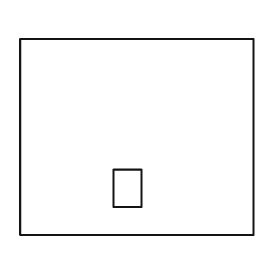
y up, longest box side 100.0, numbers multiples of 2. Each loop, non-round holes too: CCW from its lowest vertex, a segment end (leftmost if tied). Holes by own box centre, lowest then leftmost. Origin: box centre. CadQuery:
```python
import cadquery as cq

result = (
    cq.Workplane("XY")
    .moveTo(-50.0, -42.0)
    .lineTo(50.0, -42.0)
    .lineTo(50.0, 42.0)
    .lineTo(-50.0, 42.0)
    .close()
    .moveTo(-10.0, -30.0)
    .lineTo(2.0, -30.0)
    .lineTo(2.0, -14.0)
    .lineTo(-10.0, -14.0)
    .close()
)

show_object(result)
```